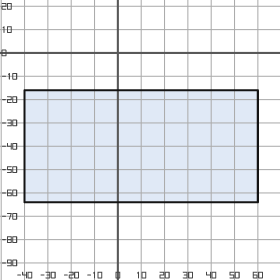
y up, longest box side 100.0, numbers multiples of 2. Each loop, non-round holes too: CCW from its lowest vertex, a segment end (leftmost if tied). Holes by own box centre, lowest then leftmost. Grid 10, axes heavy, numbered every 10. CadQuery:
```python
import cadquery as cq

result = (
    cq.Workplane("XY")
    .moveTo(-40.0, -64.0)
    .lineTo(60.0, -64.0)
    .lineTo(60.0, -16.0)
    .lineTo(-40.0, -16.0)
    .close()
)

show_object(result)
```